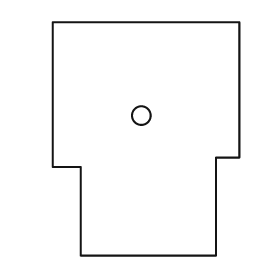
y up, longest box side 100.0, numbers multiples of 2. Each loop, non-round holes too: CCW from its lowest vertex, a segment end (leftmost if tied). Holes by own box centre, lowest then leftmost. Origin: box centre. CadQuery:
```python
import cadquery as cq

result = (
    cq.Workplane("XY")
    .moveTo(-28.0, -50.0)
    .lineTo(30.0, -50.0)
    .lineTo(30.0, -8.0)
    .lineTo(40.0, -8.0)
    .lineTo(40.0, 50.0)
    .lineTo(-40.0, 50.0)
    .lineTo(-40.0, -12.0)
    .lineTo(-28.0, -12.0)
    .close()
    .moveTo(-2.0, 10.0)
    .circle(4.0)
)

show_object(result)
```